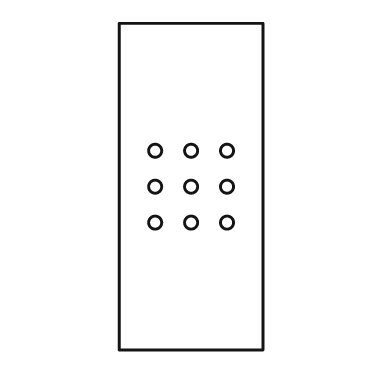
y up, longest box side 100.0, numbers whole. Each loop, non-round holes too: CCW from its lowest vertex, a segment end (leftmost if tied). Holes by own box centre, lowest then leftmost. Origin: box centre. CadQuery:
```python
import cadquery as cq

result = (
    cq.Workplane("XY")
    .moveTo(-22.0, -50.0)
    .lineTo(22.0, -50.0)
    .lineTo(22.0, 50.0)
    .lineTo(-22.0, 50.0)
    .close()
    .moveTo(-11.0, -11.0)
    .circle(2.0)
    .moveTo(0.0, -11.0)
    .circle(2.0)
    .moveTo(11.0, -11.0)
    .circle(2.0)
    .moveTo(-11.0, 0.0)
    .circle(2.0)
    .moveTo(0.0, 0.0)
    .circle(2.0)
    .moveTo(11.0, 0.0)
    .circle(2.0)
    .moveTo(-11.0, 11.0)
    .circle(2.0)
    .moveTo(0.0, 11.0)
    .circle(2.0)
    .moveTo(11.0, 11.0)
    .circle(2.0)
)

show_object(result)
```